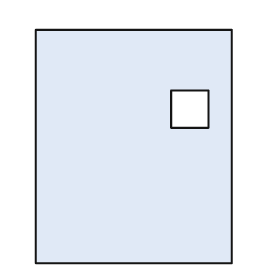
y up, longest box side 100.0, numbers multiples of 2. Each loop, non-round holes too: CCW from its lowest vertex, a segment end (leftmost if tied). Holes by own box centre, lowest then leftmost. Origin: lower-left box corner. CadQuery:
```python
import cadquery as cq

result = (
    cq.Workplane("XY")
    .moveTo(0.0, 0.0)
    .lineTo(84.0, 0.0)
    .lineTo(84.0, 100.0)
    .lineTo(0.0, 100.0)
    .close()
    .moveTo(58.0, 58.0)
    .lineTo(74.0, 58.0)
    .lineTo(74.0, 74.0)
    .lineTo(58.0, 74.0)
    .close()
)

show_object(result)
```